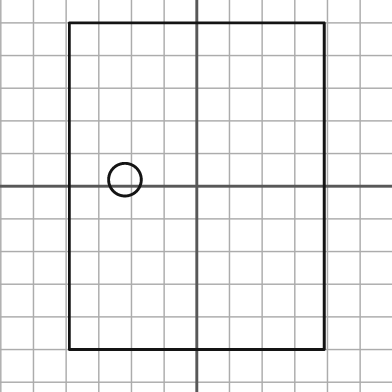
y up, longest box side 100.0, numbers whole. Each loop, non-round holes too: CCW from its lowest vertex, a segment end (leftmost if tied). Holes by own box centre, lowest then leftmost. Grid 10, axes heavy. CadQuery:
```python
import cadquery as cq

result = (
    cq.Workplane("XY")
    .moveTo(-39.0, -50.0)
    .lineTo(39.0, -50.0)
    .lineTo(39.0, 50.0)
    .lineTo(-39.0, 50.0)
    .close()
    .moveTo(-22.0, 2.0)
    .circle(5.0)
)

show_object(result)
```